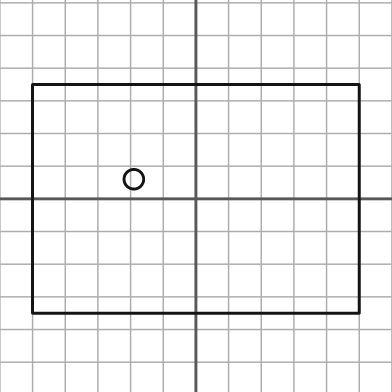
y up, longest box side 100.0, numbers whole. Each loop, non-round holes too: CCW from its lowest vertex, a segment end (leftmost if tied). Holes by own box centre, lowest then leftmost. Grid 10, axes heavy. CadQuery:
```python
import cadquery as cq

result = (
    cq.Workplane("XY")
    .moveTo(-50.0, -35.0)
    .lineTo(50.0, -35.0)
    .lineTo(50.0, 35.0)
    .lineTo(-50.0, 35.0)
    .close()
    .moveTo(-19.0, 6.0)
    .circle(3.0)
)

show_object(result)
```